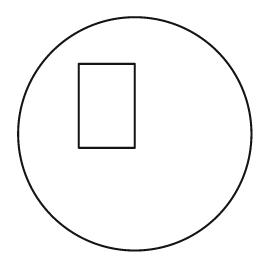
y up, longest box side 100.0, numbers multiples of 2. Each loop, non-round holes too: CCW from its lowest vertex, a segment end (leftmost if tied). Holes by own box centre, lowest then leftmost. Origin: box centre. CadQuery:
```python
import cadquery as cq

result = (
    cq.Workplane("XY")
    .moveTo(0.0, 0.0)
    .circle(50.0)
    .moveTo(-24.0, -6.0)
    .lineTo(0.0, -6.0)
    .lineTo(0.0, 30.0)
    .lineTo(-24.0, 30.0)
    .close()
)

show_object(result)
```